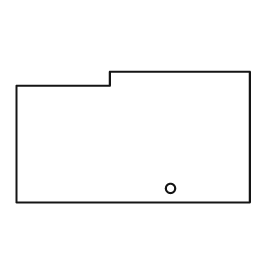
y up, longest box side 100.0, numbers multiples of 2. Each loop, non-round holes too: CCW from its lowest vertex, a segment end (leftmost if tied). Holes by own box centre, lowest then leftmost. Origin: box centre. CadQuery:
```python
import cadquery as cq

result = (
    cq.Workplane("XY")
    .moveTo(-50.0, -28.0)
    .lineTo(50.0, -28.0)
    .lineTo(50.0, 28.0)
    .lineTo(-10.0, 28.0)
    .lineTo(-10.0, 22.0)
    .lineTo(-50.0, 22.0)
    .close()
    .moveTo(16.0, -22.0)
    .circle(2.0)
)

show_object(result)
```